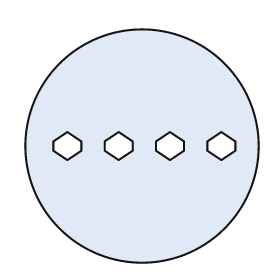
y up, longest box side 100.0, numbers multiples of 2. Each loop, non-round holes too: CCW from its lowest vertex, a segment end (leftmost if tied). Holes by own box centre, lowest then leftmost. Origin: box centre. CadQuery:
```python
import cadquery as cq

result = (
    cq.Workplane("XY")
    .moveTo(0.0, 0.0)
    .circle(50.0)
    .moveTo(-32.0, -6.0)
    .lineTo(-26.0, -2.0)
    .lineTo(-26.0, 2.0)
    .lineTo(-32.0, 6.0)
    .lineTo(-38.0, 2.0)
    .lineTo(-38.0, -2.0)
    .close()
    .moveTo(-10.0, -6.0)
    .lineTo(-4.0, -2.0)
    .lineTo(-4.0, 2.0)
    .lineTo(-10.0, 6.0)
    .lineTo(-16.0, 2.0)
    .lineTo(-16.0, -2.0)
    .close()
    .moveTo(12.0, -6.0)
    .lineTo(18.0, -2.0)
    .lineTo(18.0, 2.0)
    .lineTo(12.0, 6.0)
    .lineTo(6.0, 2.0)
    .lineTo(6.0, -2.0)
    .close()
    .moveTo(34.0, -6.0)
    .lineTo(40.0, -2.0)
    .lineTo(40.0, 2.0)
    .lineTo(34.0, 6.0)
    .lineTo(28.0, 2.0)
    .lineTo(28.0, -2.0)
    .close()
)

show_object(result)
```